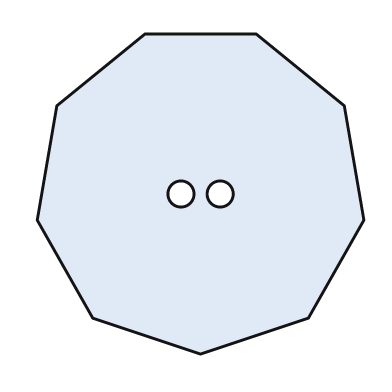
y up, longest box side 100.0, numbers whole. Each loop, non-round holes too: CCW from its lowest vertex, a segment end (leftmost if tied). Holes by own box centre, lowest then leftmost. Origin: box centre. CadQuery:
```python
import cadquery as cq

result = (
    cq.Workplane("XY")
    .moveTo(0.0, -49.0)
    .lineTo(33.0, -38.0)
    .lineTo(50.0, -8.0)
    .lineTo(44.0, 27.0)
    .lineTo(17.0, 49.0)
    .lineTo(-17.0, 49.0)
    .lineTo(-44.0, 27.0)
    .lineTo(-50.0, -8.0)
    .lineTo(-33.0, -38.0)
    .close()
    .moveTo(-6.0, 0.0)
    .circle(4.0)
    .moveTo(6.0, 0.0)
    .circle(4.0)
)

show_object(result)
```